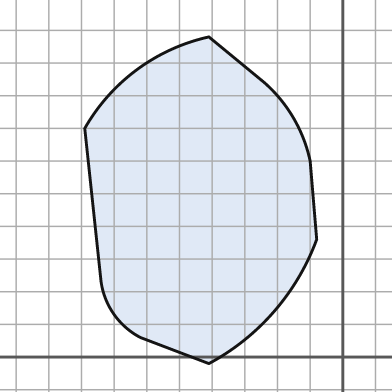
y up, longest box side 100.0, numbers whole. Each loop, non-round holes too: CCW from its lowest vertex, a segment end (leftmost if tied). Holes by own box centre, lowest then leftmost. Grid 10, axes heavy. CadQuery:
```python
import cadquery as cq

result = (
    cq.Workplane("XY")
    .moveTo(-41.0, -2.0)
    .threePointArc((-21.0, 14.0), (-8.0, 36.0))
    .lineTo(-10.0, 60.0)
    .threePointArc((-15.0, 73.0), (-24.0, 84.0))
    .lineTo(-41.0, 98.0)
    .threePointArc((-63.0, 88.0), (-79.0, 70.0))
    .lineTo(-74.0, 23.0)
    .threePointArc((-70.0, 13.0), (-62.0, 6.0))
    .close()
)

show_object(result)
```